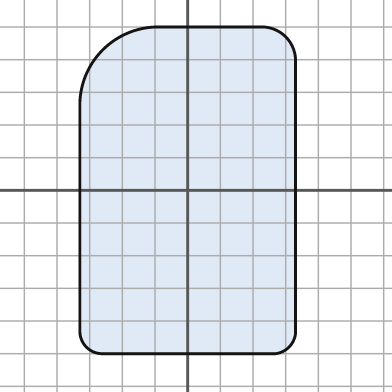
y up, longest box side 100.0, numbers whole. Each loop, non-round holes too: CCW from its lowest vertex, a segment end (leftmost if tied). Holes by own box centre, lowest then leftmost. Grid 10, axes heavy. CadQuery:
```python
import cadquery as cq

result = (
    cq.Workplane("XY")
    .moveTo(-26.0, -50.0)
    .lineTo(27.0, -50.0)
    .threePointArc((31.0, -48.0), (33.0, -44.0))
    .lineTo(33.0, 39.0)
    .threePointArc((30.0, 47.0), (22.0, 50.0))
    .lineTo(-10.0, 50.0)
    .threePointArc((-26.0, 43.0), (-33.0, 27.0))
    .lineTo(-33.0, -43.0)
    .threePointArc((-31.0, -48.0), (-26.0, -50.0))
    .close()
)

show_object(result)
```